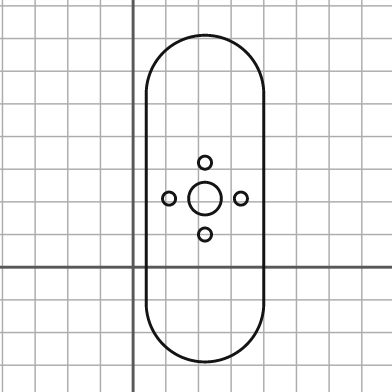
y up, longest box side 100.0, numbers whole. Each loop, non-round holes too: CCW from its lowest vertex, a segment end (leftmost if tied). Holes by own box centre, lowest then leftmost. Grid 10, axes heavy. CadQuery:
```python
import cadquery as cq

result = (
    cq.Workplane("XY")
    .moveTo(4.0, -11.0)
    .threePointArc((22.0, -29.0), (40.0, -11.0))
    .lineTo(40.0, 53.0)
    .threePointArc((22.0, 71.0), (4.0, 53.0))
    .close()
    .moveTo(22.0, 10.0)
    .circle(2.0)
    .moveTo(11.0, 21.0)
    .circle(2.0)
    .moveTo(22.0, 21.0)
    .circle(5.0)
    .moveTo(33.0, 21.0)
    .circle(2.0)
    .moveTo(22.0, 32.0)
    .circle(2.0)
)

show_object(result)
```